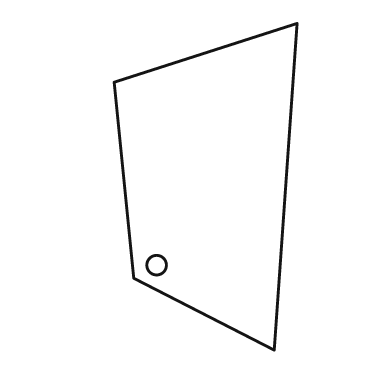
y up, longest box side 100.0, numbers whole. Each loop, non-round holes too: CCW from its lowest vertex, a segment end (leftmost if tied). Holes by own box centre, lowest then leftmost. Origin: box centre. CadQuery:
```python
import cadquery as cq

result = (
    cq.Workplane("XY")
    .moveTo(21.0, -50.0)
    .lineTo(28.0, 50.0)
    .lineTo(-28.0, 32.0)
    .lineTo(-22.0, -28.0)
    .close()
    .moveTo(-15.0, -24.0)
    .circle(3.0)
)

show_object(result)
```